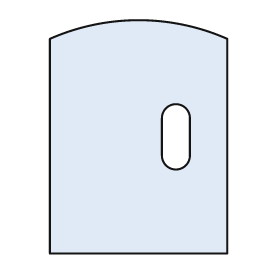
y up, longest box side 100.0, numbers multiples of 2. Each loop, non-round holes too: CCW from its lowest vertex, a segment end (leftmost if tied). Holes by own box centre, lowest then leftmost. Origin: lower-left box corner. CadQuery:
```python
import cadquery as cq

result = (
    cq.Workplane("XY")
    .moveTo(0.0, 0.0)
    .lineTo(76.0, 0.0)
    .lineTo(76.0, 92.0)
    .threePointArc((38.0, 100.0), (0.0, 92.0))
    .close()
    .moveTo(48.0, 42.0)
    .threePointArc((54.0, 36.0), (60.0, 42.0))
    .lineTo(60.0, 58.0)
    .threePointArc((54.0, 64.0), (48.0, 58.0))
    .close()
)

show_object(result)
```